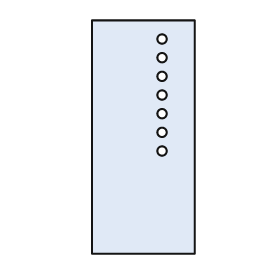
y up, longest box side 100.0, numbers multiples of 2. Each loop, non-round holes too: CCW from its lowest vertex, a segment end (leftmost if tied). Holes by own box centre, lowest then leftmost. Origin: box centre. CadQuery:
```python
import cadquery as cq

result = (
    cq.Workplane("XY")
    .moveTo(-22.0, -50.0)
    .lineTo(22.0, -50.0)
    .lineTo(22.0, 50.0)
    .lineTo(-22.0, 50.0)
    .close()
    .moveTo(8.0, -6.0)
    .circle(2.0)
    .moveTo(8.0, 2.0)
    .circle(2.0)
    .moveTo(8.0, 10.0)
    .circle(2.0)
    .moveTo(8.0, 18.0)
    .circle(2.0)
    .moveTo(8.0, 26.0)
    .circle(2.0)
    .moveTo(8.0, 34.0)
    .circle(2.0)
    .moveTo(8.0, 42.0)
    .circle(2.0)
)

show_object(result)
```